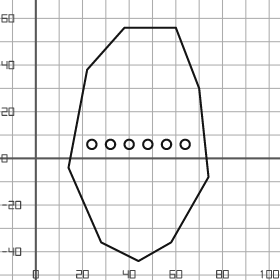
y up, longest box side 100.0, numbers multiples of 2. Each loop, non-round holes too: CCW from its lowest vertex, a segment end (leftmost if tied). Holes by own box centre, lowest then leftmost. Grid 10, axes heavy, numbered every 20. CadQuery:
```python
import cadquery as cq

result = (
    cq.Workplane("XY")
    .moveTo(44.0, -44.0)
    .lineTo(58.0, -36.0)
    .lineTo(74.0, -8.0)
    .lineTo(70.0, 30.0)
    .lineTo(60.0, 56.0)
    .lineTo(38.0, 56.0)
    .lineTo(22.0, 38.0)
    .lineTo(14.0, -4.0)
    .lineTo(28.0, -36.0)
    .close()
    .moveTo(24.0, 6.0)
    .circle(2.0)
    .moveTo(32.0, 6.0)
    .circle(2.0)
    .moveTo(40.0, 6.0)
    .circle(2.0)
    .moveTo(48.0, 6.0)
    .circle(2.0)
    .moveTo(56.0, 6.0)
    .circle(2.0)
    .moveTo(64.0, 6.0)
    .circle(2.0)
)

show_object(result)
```